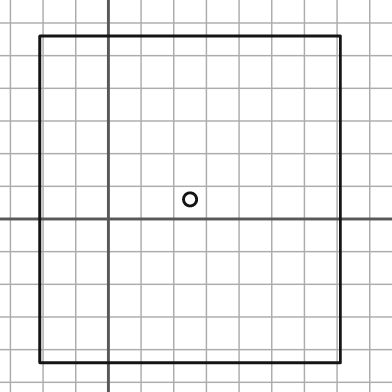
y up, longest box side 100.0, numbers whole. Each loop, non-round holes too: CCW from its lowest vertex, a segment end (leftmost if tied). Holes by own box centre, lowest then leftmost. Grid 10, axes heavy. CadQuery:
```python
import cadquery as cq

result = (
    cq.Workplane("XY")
    .moveTo(-21.0, -44.0)
    .lineTo(71.0, -44.0)
    .lineTo(71.0, 56.0)
    .lineTo(-21.0, 56.0)
    .close()
    .moveTo(25.0, 6.0)
    .circle(2.0)
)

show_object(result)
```